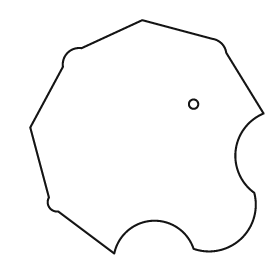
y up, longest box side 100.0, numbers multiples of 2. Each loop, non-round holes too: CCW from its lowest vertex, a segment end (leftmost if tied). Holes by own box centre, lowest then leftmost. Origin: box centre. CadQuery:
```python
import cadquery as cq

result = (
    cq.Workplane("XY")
    .moveTo(-14.0, -50.0)
    .threePointArc((2.0, -36.0), (20.0, -48.0))
    .threePointArc((40.0, -44.0), (46.0, -24.0))
    .threePointArc((38.0, -6.0), (50.0, 10.0))
    .lineTo(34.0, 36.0)
    .threePointArc((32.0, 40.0), (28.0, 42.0))
    .lineTo(-2.0, 50.0)
    .lineTo(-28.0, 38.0)
    .threePointArc((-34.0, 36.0), (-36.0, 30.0))
    .lineTo(-50.0, 4.0)
    .lineTo(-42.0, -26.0)
    .threePointArc((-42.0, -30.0), (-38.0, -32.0))
    .close()
    .moveTo(20.0, 14.0)
    .circle(2.0)
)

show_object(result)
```